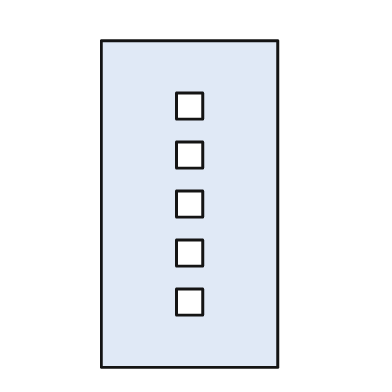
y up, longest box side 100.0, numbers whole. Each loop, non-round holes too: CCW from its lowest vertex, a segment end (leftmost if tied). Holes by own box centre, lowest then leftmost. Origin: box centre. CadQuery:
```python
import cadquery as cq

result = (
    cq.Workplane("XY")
    .moveTo(-27.0, -50.0)
    .lineTo(27.0, -50.0)
    .lineTo(27.0, 50.0)
    .lineTo(-27.0, 50.0)
    .close()
    .moveTo(-4.0, -34.0)
    .lineTo(4.0, -34.0)
    .lineTo(4.0, -26.0)
    .lineTo(-4.0, -26.0)
    .close()
    .moveTo(-4.0, -19.0)
    .lineTo(4.0, -19.0)
    .lineTo(4.0, -11.0)
    .lineTo(-4.0, -11.0)
    .close()
    .moveTo(-4.0, -4.0)
    .lineTo(4.0, -4.0)
    .lineTo(4.0, 4.0)
    .lineTo(-4.0, 4.0)
    .close()
    .moveTo(-4.0, 11.0)
    .lineTo(4.0, 11.0)
    .lineTo(4.0, 19.0)
    .lineTo(-4.0, 19.0)
    .close()
    .moveTo(-4.0, 26.0)
    .lineTo(4.0, 26.0)
    .lineTo(4.0, 34.0)
    .lineTo(-4.0, 34.0)
    .close()
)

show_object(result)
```